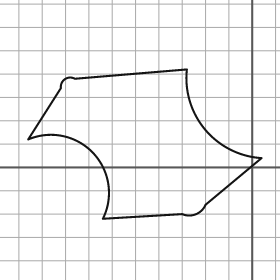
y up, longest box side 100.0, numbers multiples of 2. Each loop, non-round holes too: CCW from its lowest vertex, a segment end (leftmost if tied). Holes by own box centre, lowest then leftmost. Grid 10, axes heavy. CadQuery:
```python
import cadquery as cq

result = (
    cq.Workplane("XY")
    .moveTo(-64.0, -22.0)
    .lineTo(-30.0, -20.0)
    .threePointArc((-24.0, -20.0), (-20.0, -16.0))
    .lineTo(4.0, 4.0)
    .threePointArc((-20.0, 16.0), (-28.0, 42.0))
    .lineTo(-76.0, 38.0)
    .threePointArc((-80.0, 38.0), (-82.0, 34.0))
    .lineTo(-96.0, 12.0)
    .threePointArc((-68.0, 6.0), (-64.0, -22.0))
    .close()
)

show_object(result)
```